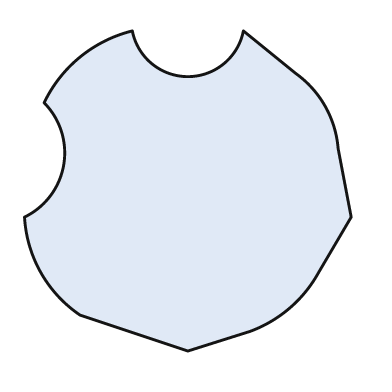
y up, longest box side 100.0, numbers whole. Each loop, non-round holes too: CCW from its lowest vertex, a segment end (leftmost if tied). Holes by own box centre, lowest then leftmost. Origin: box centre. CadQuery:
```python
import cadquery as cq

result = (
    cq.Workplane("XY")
    .moveTo(0.0, -49.0)
    .lineTo(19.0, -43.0)
    .threePointArc((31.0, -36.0), (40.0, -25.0))
    .lineTo(50.0, -8.0)
    .lineTo(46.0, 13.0)
    .threePointArc((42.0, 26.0), (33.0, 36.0))
    .lineTo(17.0, 49.0)
    .threePointArc((0.0, 35.0), (-17.0, 49.0))
    .threePointArc((-33.0, 41.0), (-44.0, 27.0))
    .threePointArc((-38.0, 8.0), (-50.0, -8.0))
    .threePointArc((-45.0, -25.0), (-33.0, -38.0))
    .close()
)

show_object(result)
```